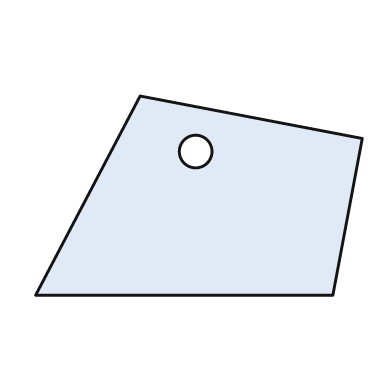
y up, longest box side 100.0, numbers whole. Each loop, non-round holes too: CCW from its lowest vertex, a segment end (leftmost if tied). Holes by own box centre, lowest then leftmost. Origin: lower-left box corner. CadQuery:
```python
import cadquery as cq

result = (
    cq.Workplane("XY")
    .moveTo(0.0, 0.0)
    .lineTo(91.0, 0.0)
    .lineTo(100.0, 48.0)
    .lineTo(32.0, 61.0)
    .close()
    .moveTo(49.0, 44.0)
    .circle(5.0)
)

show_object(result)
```